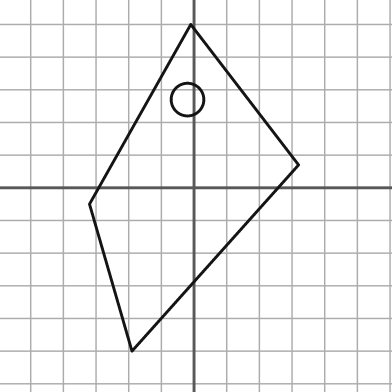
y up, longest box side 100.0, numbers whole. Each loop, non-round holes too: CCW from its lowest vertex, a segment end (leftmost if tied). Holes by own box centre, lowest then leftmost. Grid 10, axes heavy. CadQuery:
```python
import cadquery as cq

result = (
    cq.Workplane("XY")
    .moveTo(-19.0, -50.0)
    .lineTo(32.0, 7.0)
    .lineTo(-1.0, 50.0)
    .lineTo(-32.0, -5.0)
    .close()
    .moveTo(-2.0, 27.0)
    .circle(5.0)
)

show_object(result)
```